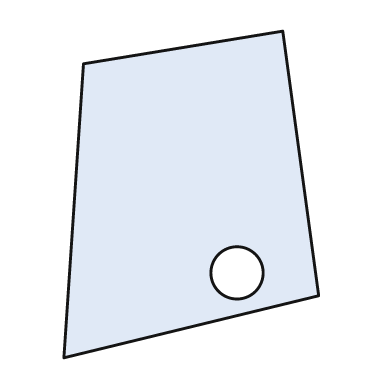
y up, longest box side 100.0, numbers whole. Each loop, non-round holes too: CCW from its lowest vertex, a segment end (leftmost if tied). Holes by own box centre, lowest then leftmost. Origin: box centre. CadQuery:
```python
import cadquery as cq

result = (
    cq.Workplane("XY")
    .moveTo(-39.0, -50.0)
    .lineTo(39.0, -31.0)
    .lineTo(28.0, 50.0)
    .lineTo(-33.0, 40.0)
    .close()
    .moveTo(14.0, -24.0)
    .circle(8.0)
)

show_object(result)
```